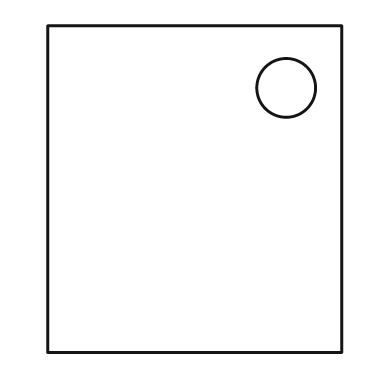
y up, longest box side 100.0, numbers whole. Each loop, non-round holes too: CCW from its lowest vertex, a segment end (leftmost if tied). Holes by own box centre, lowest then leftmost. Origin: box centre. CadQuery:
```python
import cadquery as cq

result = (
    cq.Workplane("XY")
    .moveTo(-45.0, -50.0)
    .lineTo(45.0, -50.0)
    .lineTo(45.0, 50.0)
    .lineTo(-45.0, 50.0)
    .close()
    .moveTo(28.0, 31.0)
    .circle(9.0)
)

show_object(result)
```